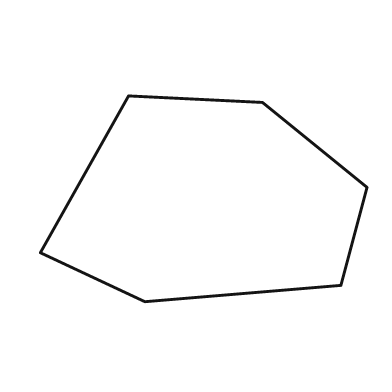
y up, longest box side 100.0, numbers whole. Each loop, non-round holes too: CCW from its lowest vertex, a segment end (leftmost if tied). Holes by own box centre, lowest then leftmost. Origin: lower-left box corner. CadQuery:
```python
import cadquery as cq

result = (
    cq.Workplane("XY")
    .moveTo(32.0, 0.0)
    .lineTo(92.0, 5.0)
    .lineTo(100.0, 35.0)
    .lineTo(68.0, 61.0)
    .lineTo(27.0, 63.0)
    .lineTo(0.0, 15.0)
    .close()
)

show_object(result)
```